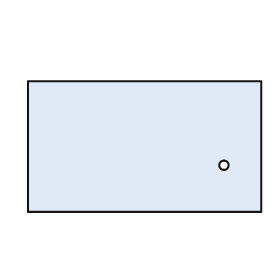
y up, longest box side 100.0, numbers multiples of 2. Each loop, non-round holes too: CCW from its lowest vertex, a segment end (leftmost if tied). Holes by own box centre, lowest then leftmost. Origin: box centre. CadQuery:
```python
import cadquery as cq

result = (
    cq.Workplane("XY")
    .moveTo(-50.0, -28.0)
    .lineTo(50.0, -28.0)
    .lineTo(50.0, 28.0)
    .lineTo(-50.0, 28.0)
    .close()
    .moveTo(34.0, -8.0)
    .circle(2.0)
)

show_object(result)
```